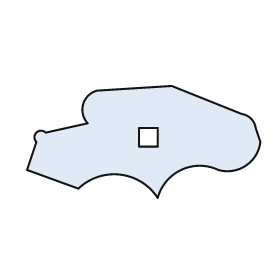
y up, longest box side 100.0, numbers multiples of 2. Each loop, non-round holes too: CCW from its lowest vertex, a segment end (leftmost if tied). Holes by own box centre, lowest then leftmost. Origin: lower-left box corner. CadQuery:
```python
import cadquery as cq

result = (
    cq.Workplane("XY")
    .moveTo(56.0, 0.0)
    .threePointArc((66.0, 12.0), (82.0, 12.0))
    .threePointArc((94.0, 14.0), (100.0, 24.0))
    .lineTo(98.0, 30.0)
    .threePointArc((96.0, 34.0), (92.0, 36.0))
    .lineTo(62.0, 48.0)
    .lineTo(30.0, 46.0)
    .threePointArc((24.0, 40.0), (26.0, 32.0))
    .lineTo(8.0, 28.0)
    .threePointArc((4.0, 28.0), (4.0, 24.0))
    .lineTo(0.0, 12.0)
    .lineTo(22.0, 4.0)
    .threePointArc((40.0, 10.0), (56.0, 0.0))
    .close()
    .moveTo(48.0, 22.0)
    .lineTo(56.0, 22.0)
    .lineTo(56.0, 30.0)
    .lineTo(48.0, 30.0)
    .close()
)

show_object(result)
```